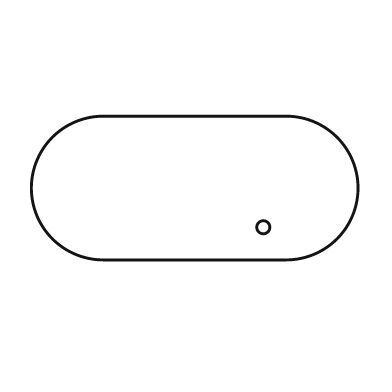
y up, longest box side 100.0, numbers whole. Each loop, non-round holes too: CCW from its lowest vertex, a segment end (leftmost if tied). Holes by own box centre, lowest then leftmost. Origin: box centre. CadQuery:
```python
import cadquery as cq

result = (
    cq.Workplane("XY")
    .moveTo(-28.0, -22.0)
    .lineTo(28.0, -22.0)
    .threePointArc((50.0, 0.0), (28.0, 22.0))
    .lineTo(-28.0, 22.0)
    .threePointArc((-50.0, 0.0), (-28.0, -22.0))
    .close()
    .moveTo(21.0, -12.0)
    .circle(2.0)
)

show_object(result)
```